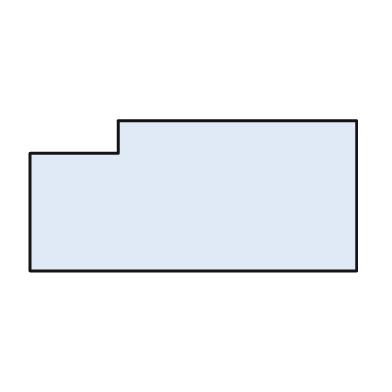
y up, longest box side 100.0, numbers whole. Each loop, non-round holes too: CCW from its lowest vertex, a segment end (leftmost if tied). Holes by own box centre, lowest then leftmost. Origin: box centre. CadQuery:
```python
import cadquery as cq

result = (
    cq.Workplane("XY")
    .moveTo(-50.0, -23.0)
    .lineTo(50.0, -23.0)
    .lineTo(50.0, 23.0)
    .lineTo(-23.0, 23.0)
    .lineTo(-23.0, 13.0)
    .lineTo(-50.0, 13.0)
    .close()
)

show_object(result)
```